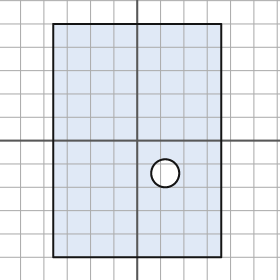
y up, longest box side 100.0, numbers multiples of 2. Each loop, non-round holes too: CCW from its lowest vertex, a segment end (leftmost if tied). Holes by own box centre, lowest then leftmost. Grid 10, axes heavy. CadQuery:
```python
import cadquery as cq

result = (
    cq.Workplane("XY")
    .moveTo(-36.0, -50.0)
    .lineTo(36.0, -50.0)
    .lineTo(36.0, 50.0)
    .lineTo(-36.0, 50.0)
    .close()
    .moveTo(12.0, -14.0)
    .circle(6.0)
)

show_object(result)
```